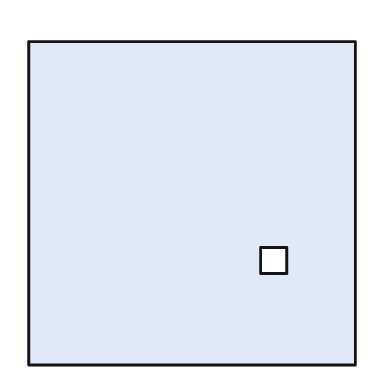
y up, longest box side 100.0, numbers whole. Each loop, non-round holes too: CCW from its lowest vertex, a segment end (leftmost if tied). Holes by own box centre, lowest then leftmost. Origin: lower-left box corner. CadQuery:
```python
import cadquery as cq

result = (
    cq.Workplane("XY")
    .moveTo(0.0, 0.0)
    .lineTo(100.0, 0.0)
    .lineTo(100.0, 99.0)
    .lineTo(0.0, 99.0)
    .close()
    .moveTo(71.0, 28.0)
    .lineTo(79.0, 28.0)
    .lineTo(79.0, 36.0)
    .lineTo(71.0, 36.0)
    .close()
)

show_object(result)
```